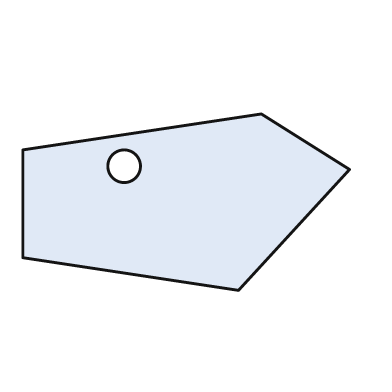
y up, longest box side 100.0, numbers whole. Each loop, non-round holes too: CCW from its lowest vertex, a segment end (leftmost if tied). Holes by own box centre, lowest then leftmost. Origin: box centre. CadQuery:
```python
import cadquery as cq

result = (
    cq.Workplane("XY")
    .moveTo(16.0, -27.0)
    .lineTo(50.0, 10.0)
    .lineTo(23.0, 27.0)
    .lineTo(-50.0, 16.0)
    .lineTo(-50.0, -17.0)
    .close()
    .moveTo(-19.0, 11.0)
    .circle(5.0)
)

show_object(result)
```